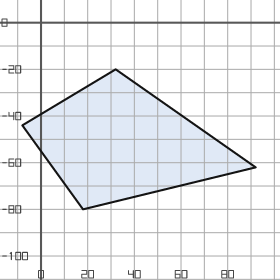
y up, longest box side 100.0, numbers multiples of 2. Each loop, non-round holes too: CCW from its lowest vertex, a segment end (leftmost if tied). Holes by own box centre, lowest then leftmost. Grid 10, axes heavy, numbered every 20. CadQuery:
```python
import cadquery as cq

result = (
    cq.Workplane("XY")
    .moveTo(18.0, -80.0)
    .lineTo(92.0, -62.0)
    .lineTo(32.0, -20.0)
    .lineTo(-8.0, -44.0)
    .close()
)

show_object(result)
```